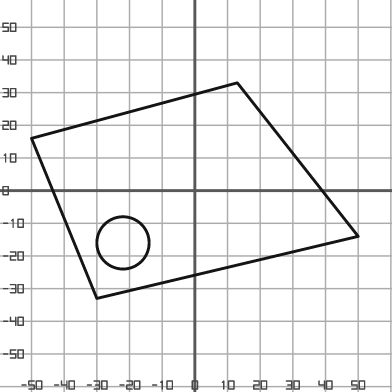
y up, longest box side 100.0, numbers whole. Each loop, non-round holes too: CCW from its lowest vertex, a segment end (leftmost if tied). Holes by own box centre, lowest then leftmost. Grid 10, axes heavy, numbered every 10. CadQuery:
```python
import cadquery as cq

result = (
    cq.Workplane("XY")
    .moveTo(-30.0, -33.0)
    .lineTo(50.0, -14.0)
    .lineTo(13.0, 33.0)
    .lineTo(-50.0, 16.0)
    .close()
    .moveTo(-22.0, -16.0)
    .circle(8.0)
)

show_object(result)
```